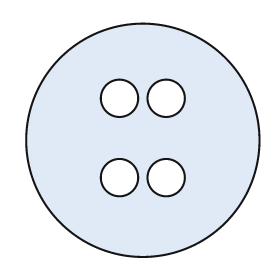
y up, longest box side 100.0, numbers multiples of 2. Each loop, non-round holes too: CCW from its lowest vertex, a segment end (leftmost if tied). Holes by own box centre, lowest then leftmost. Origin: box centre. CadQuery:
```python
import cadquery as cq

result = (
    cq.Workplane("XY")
    .moveTo(0.0, 0.0)
    .circle(50.0)
    .moveTo(-10.0, -16.0)
    .circle(8.0)
    .moveTo(10.0, -16.0)
    .circle(8.0)
    .moveTo(-10.0, 18.0)
    .circle(8.0)
    .moveTo(10.0, 18.0)
    .circle(8.0)
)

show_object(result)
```